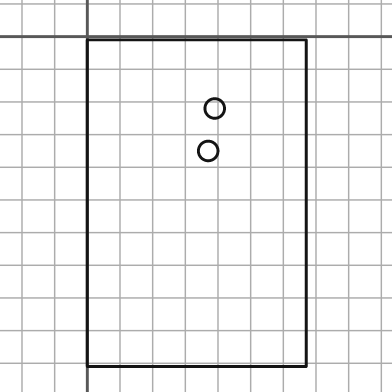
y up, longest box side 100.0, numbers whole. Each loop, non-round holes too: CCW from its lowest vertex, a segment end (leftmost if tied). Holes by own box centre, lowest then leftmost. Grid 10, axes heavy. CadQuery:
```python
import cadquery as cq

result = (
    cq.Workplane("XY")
    .moveTo(0.0, -101.0)
    .lineTo(67.0, -101.0)
    .lineTo(67.0, -1.0)
    .lineTo(0.0, -1.0)
    .close()
    .moveTo(37.0, -35.0)
    .circle(3.0)
    .moveTo(39.0, -22.0)
    .circle(3.0)
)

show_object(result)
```